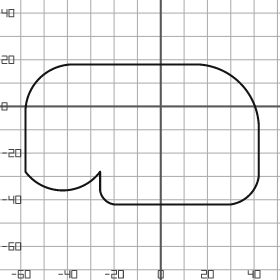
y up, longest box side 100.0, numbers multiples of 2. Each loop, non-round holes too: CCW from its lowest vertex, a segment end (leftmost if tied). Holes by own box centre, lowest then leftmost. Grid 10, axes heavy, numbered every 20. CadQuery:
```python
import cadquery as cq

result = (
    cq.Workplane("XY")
    .moveTo(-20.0, -42.0)
    .lineTo(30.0, -42.0)
    .threePointArc((38.0, -38.0), (42.0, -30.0))
    .lineTo(42.0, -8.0)
    .threePointArc((34.0, 10.0), (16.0, 18.0))
    .lineTo(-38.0, 18.0)
    .threePointArc((-52.0, 12.0), (-58.0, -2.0))
    .lineTo(-58.0, -28.0)
    .threePointArc((-42.0, -36.0), (-26.0, -28.0))
    .lineTo(-26.0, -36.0)
    .threePointArc((-24.0, -40.0), (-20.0, -42.0))
    .close()
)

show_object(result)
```